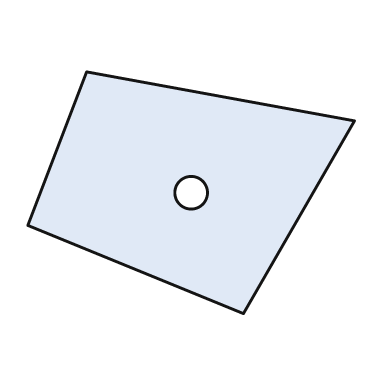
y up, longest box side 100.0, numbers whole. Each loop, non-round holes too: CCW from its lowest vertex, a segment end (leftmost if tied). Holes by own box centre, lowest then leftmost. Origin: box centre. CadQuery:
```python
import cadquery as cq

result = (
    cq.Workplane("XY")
    .moveTo(16.0, -37.0)
    .lineTo(50.0, 22.0)
    .lineTo(-32.0, 37.0)
    .lineTo(-50.0, -10.0)
    .close()
    .moveTo(0.0, 0.0)
    .circle(5.0)
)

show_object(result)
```